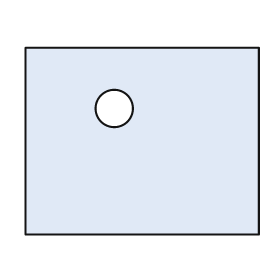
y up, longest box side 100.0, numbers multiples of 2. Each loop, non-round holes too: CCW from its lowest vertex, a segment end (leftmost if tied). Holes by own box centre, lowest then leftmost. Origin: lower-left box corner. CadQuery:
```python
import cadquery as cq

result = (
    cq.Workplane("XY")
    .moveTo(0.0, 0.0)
    .lineTo(100.0, 0.0)
    .lineTo(100.0, 80.0)
    .lineTo(0.0, 80.0)
    .close()
    .moveTo(38.0, 54.0)
    .circle(8.0)
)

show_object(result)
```